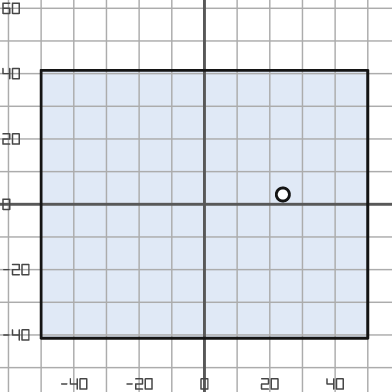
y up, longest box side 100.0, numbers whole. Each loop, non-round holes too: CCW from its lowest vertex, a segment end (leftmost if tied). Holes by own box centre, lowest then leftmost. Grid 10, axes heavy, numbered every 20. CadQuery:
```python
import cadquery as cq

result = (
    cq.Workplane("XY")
    .moveTo(-50.0, -41.0)
    .lineTo(50.0, -41.0)
    .lineTo(50.0, 41.0)
    .lineTo(-50.0, 41.0)
    .close()
    .moveTo(24.0, 3.0)
    .circle(2.0)
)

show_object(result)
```